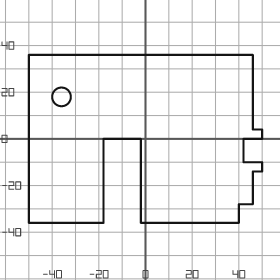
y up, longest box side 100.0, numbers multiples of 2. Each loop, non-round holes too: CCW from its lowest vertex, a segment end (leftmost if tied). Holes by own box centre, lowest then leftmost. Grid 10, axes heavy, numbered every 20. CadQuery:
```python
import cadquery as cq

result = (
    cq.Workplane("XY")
    .moveTo(-50.0, -36.0)
    .lineTo(-18.0, -36.0)
    .lineTo(-18.0, 0.0)
    .lineTo(-2.0, 0.0)
    .lineTo(-2.0, -36.0)
    .lineTo(40.0, -36.0)
    .lineTo(40.0, -28.0)
    .lineTo(46.0, -28.0)
    .lineTo(46.0, -14.0)
    .lineTo(50.0, -14.0)
    .lineTo(50.0, -10.0)
    .lineTo(42.0, -10.0)
    .lineTo(42.0, 0.0)
    .lineTo(50.0, 0.0)
    .lineTo(50.0, 4.0)
    .lineTo(46.0, 4.0)
    .lineTo(46.0, 36.0)
    .lineTo(-50.0, 36.0)
    .close()
    .moveTo(-36.0, 18.0)
    .circle(4.0)
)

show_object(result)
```